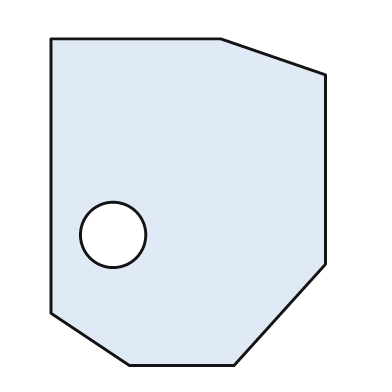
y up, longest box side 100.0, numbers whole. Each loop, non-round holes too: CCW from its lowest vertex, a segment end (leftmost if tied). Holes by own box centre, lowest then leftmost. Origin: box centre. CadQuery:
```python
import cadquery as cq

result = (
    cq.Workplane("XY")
    .moveTo(-18.0, -50.0)
    .lineTo(14.0, -50.0)
    .lineTo(42.0, -19.0)
    .lineTo(42.0, 39.0)
    .lineTo(10.0, 50.0)
    .lineTo(-42.0, 50.0)
    .lineTo(-42.0, -34.0)
    .close()
    .moveTo(-23.0, -10.0)
    .circle(10.0)
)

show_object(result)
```